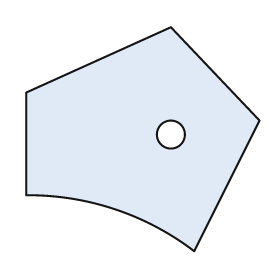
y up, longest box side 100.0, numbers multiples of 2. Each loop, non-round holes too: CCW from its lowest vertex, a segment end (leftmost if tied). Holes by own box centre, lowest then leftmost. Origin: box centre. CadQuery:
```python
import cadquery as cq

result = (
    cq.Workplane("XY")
    .moveTo(22.0, -48.0)
    .lineTo(50.0, 8.0)
    .lineTo(12.0, 48.0)
    .lineTo(-50.0, 20.0)
    .lineTo(-50.0, -24.0)
    .threePointArc((-12.0, -30.0), (22.0, -48.0))
    .close()
    .moveTo(12.0, 2.0)
    .circle(6.0)
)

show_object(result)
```